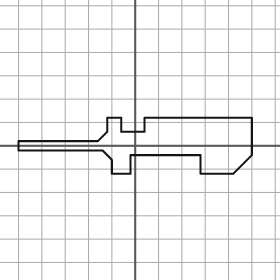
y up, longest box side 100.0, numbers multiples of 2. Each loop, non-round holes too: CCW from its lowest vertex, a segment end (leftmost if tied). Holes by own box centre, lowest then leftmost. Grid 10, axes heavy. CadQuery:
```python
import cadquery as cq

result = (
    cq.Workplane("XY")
    .moveTo(-10.0, -12.0)
    .lineTo(-2.0, -12.0)
    .lineTo(-2.0, -4.0)
    .lineTo(28.0, -4.0)
    .lineTo(28.0, -12.0)
    .lineTo(42.0, -12.0)
    .lineTo(50.0, -4.0)
    .lineTo(50.0, 12.0)
    .lineTo(4.0, 12.0)
    .lineTo(4.0, 6.0)
    .lineTo(-6.0, 6.0)
    .lineTo(-6.0, 12.0)
    .lineTo(-12.0, 12.0)
    .lineTo(-12.0, 6.0)
    .lineTo(-16.0, 2.0)
    .lineTo(-50.0, 2.0)
    .lineTo(-50.0, -2.0)
    .lineTo(-14.0, -2.0)
    .lineTo(-10.0, -6.0)
    .close()
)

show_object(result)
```